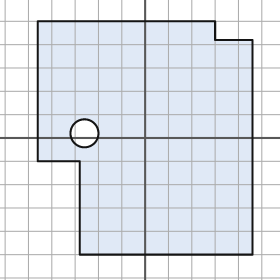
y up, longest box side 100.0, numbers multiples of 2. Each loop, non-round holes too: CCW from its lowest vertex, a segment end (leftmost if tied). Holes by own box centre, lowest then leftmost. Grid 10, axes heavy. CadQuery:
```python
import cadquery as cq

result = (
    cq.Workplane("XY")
    .moveTo(-28.0, -50.0)
    .lineTo(46.0, -50.0)
    .lineTo(46.0, 42.0)
    .lineTo(30.0, 42.0)
    .lineTo(30.0, 50.0)
    .lineTo(-46.0, 50.0)
    .lineTo(-46.0, -10.0)
    .lineTo(-28.0, -10.0)
    .close()
    .moveTo(-26.0, 2.0)
    .circle(6.0)
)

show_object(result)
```